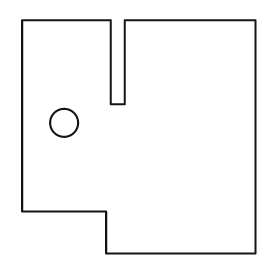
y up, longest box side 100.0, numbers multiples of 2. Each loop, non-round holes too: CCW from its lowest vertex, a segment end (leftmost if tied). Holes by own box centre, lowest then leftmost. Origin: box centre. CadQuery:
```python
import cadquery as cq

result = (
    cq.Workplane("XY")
    .moveTo(-14.0, -50.0)
    .lineTo(50.0, -50.0)
    .lineTo(50.0, 50.0)
    .lineTo(-6.0, 50.0)
    .lineTo(-6.0, 14.0)
    .lineTo(-12.0, 14.0)
    .lineTo(-12.0, 50.0)
    .lineTo(-50.0, 50.0)
    .lineTo(-50.0, -32.0)
    .lineTo(-14.0, -32.0)
    .close()
    .moveTo(-32.0, 6.0)
    .circle(6.0)
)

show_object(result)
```